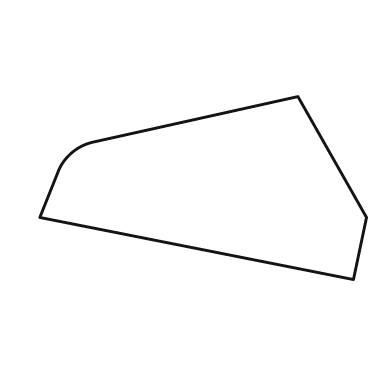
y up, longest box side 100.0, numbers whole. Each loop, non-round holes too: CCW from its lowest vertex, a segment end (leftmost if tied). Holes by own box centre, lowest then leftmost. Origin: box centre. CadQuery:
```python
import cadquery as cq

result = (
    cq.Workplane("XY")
    .moveTo(46.0, -28.0)
    .lineTo(50.0, -9.0)
    .lineTo(29.0, 28.0)
    .lineTo(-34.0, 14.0)
    .threePointArc((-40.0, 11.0), (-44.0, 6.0))
    .lineTo(-50.0, -9.0)
    .close()
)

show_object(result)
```